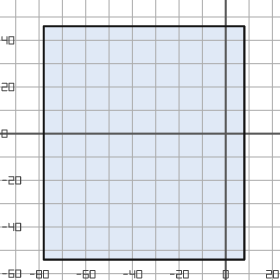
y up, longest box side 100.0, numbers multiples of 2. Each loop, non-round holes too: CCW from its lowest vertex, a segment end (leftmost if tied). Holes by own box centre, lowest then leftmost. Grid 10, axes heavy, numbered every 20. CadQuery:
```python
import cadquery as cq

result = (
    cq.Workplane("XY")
    .moveTo(-78.0, -54.0)
    .lineTo(8.0, -54.0)
    .lineTo(8.0, 46.0)
    .lineTo(-78.0, 46.0)
    .close()
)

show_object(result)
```